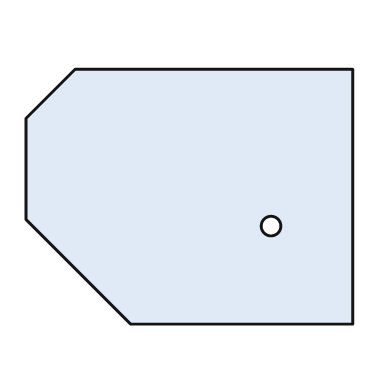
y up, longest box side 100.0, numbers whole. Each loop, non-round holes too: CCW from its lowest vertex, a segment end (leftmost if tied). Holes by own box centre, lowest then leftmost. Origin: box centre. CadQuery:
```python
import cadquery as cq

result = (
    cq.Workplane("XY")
    .moveTo(-18.0, -39.0)
    .lineTo(50.0, -39.0)
    .lineTo(50.0, 39.0)
    .lineTo(-35.0, 39.0)
    .lineTo(-50.0, 24.0)
    .lineTo(-50.0, -7.0)
    .close()
    .moveTo(25.0, -9.0)
    .circle(3.0)
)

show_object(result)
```